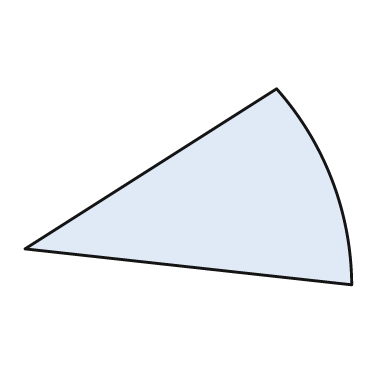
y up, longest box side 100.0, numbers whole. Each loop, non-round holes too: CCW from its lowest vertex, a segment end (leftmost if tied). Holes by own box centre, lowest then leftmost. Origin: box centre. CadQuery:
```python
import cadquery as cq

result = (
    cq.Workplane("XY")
    .moveTo(50.0, -30.0)
    .threePointArc((44.0, 2.0), (27.0, 30.0))
    .lineTo(-50.0, -19.0)
    .close()
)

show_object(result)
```